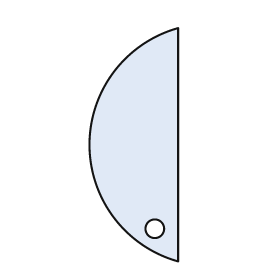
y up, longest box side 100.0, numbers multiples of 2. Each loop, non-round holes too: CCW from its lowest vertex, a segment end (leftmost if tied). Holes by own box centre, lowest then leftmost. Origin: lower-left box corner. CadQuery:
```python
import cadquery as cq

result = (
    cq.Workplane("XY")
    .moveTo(38.0, 0.0)
    .lineTo(38.0, 100.0)
    .threePointArc((0.0, 50.0), (38.0, 0.0))
    .close()
    .moveTo(28.0, 14.0)
    .circle(4.0)
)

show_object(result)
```